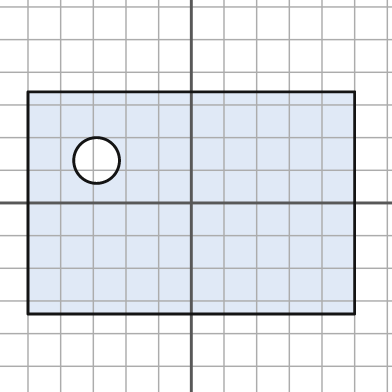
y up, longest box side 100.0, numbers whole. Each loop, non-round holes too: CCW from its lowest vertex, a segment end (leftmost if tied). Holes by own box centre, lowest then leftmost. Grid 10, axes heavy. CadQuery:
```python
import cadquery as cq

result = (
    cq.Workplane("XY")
    .moveTo(-50.0, -34.0)
    .lineTo(50.0, -34.0)
    .lineTo(50.0, 34.0)
    .lineTo(-50.0, 34.0)
    .close()
    .moveTo(-29.0, 13.0)
    .circle(7.0)
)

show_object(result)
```